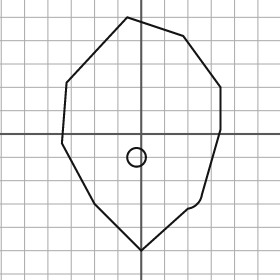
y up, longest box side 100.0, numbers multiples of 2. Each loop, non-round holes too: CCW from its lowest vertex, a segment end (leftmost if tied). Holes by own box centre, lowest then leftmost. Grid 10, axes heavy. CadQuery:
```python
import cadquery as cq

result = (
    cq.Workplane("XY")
    .moveTo(0.0, -50.0)
    .lineTo(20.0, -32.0)
    .threePointArc((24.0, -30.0), (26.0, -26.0))
    .lineTo(34.0, 2.0)
    .lineTo(34.0, 20.0)
    .lineTo(18.0, 42.0)
    .lineTo(-6.0, 50.0)
    .lineTo(-32.0, 22.0)
    .lineTo(-34.0, -4.0)
    .lineTo(-20.0, -30.0)
    .close()
    .moveTo(-2.0, -10.0)
    .circle(4.0)
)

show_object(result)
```